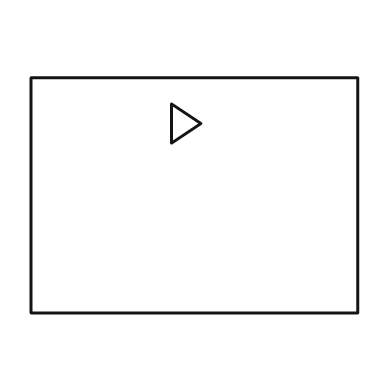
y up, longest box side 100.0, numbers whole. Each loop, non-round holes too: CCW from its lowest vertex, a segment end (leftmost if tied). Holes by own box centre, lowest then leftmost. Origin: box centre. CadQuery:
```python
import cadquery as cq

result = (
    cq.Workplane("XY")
    .moveTo(-50.0, -36.0)
    .lineTo(50.0, -36.0)
    .lineTo(50.0, 36.0)
    .lineTo(-50.0, 36.0)
    .close()
    .moveTo(-7.0, 16.0)
    .lineTo(2.0, 22.0)
    .lineTo(-7.0, 28.0)
    .close()
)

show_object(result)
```